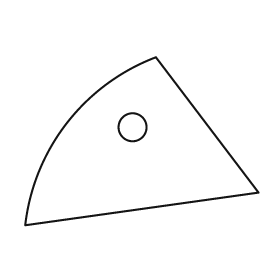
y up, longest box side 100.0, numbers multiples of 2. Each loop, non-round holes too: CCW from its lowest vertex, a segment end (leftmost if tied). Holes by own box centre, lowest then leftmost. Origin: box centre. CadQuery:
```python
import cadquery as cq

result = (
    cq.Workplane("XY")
    .moveTo(-50.0, -36.0)
    .lineTo(50.0, -22.0)
    .lineTo(6.0, 36.0)
    .threePointArc((-32.0, 8.0), (-50.0, -36.0))
    .close()
    .moveTo(-4.0, 6.0)
    .circle(6.0)
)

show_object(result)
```